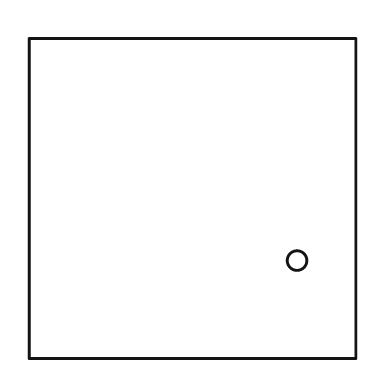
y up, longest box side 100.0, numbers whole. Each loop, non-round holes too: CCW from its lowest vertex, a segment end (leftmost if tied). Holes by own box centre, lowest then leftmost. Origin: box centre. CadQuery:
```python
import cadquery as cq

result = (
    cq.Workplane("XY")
    .moveTo(-50.0, -49.0)
    .lineTo(50.0, -49.0)
    .lineTo(50.0, 49.0)
    .lineTo(-50.0, 49.0)
    .close()
    .moveTo(32.0, -19.0)
    .circle(3.0)
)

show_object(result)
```